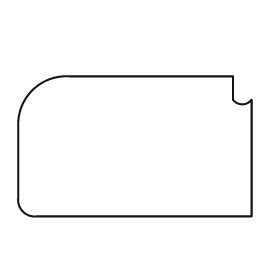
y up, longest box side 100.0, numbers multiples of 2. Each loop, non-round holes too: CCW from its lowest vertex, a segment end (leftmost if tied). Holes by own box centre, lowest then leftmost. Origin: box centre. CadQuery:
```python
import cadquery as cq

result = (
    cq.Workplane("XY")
    .moveTo(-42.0, -30.0)
    .lineTo(50.0, -30.0)
    .lineTo(50.0, 20.0)
    .threePointArc((46.0, 18.0), (42.0, 20.0))
    .lineTo(42.0, 30.0)
    .lineTo(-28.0, 30.0)
    .threePointArc((-44.0, 24.0), (-50.0, 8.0))
    .lineTo(-50.0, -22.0)
    .threePointArc((-48.0, -28.0), (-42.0, -30.0))
    .close()
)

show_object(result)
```